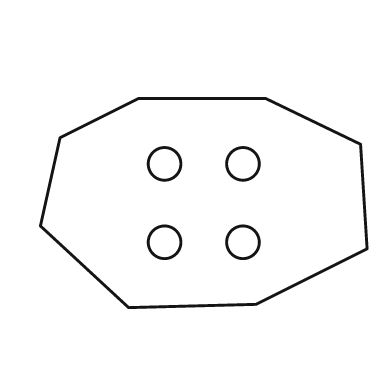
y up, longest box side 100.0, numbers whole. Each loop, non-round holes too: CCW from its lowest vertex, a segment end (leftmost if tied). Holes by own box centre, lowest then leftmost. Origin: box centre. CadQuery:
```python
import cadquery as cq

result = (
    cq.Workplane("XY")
    .moveTo(-23.0, -32.0)
    .lineTo(16.0, -31.0)
    .lineTo(50.0, -14.0)
    .lineTo(48.0, 18.0)
    .lineTo(19.0, 32.0)
    .lineTo(-20.0, 32.0)
    .lineTo(-44.0, 20.0)
    .lineTo(-50.0, -7.0)
    .close()
    .moveTo(-12.0, -12.0)
    .circle(5.0)
    .moveTo(12.0, -12.0)
    .circle(5.0)
    .moveTo(-12.0, 12.0)
    .circle(5.0)
    .moveTo(12.0, 12.0)
    .circle(5.0)
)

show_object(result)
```